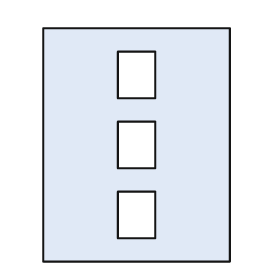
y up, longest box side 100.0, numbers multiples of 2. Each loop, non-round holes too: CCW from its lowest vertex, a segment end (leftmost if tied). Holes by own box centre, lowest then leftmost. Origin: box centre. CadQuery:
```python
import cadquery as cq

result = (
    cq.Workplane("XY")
    .moveTo(-40.0, -50.0)
    .lineTo(40.0, -50.0)
    .lineTo(40.0, 50.0)
    .lineTo(-40.0, 50.0)
    .close()
    .moveTo(-8.0, -40.0)
    .lineTo(8.0, -40.0)
    .lineTo(8.0, -20.0)
    .lineTo(-8.0, -20.0)
    .close()
    .moveTo(-8.0, -10.0)
    .lineTo(8.0, -10.0)
    .lineTo(8.0, 10.0)
    .lineTo(-8.0, 10.0)
    .close()
    .moveTo(-8.0, 20.0)
    .lineTo(8.0, 20.0)
    .lineTo(8.0, 40.0)
    .lineTo(-8.0, 40.0)
    .close()
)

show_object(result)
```